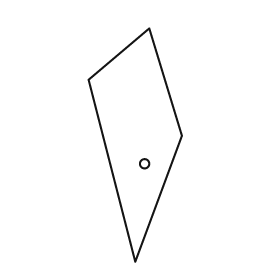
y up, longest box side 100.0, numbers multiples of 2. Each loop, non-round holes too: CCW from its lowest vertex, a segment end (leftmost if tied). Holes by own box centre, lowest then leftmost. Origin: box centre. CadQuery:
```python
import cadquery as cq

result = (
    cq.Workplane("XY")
    .moveTo(0.0, -50.0)
    .lineTo(20.0, 4.0)
    .lineTo(6.0, 50.0)
    .lineTo(-20.0, 28.0)
    .close()
    .moveTo(4.0, -8.0)
    .circle(2.0)
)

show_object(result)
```